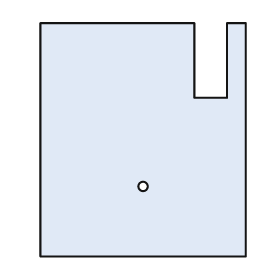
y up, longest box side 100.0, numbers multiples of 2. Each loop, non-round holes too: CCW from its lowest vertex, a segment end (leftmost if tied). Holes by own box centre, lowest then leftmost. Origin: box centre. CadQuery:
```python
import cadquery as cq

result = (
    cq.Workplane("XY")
    .moveTo(-44.0, -50.0)
    .lineTo(44.0, -50.0)
    .lineTo(44.0, 50.0)
    .lineTo(36.0, 50.0)
    .lineTo(36.0, 18.0)
    .lineTo(22.0, 18.0)
    .lineTo(22.0, 50.0)
    .lineTo(-44.0, 50.0)
    .close()
    .moveTo(0.0, -20.0)
    .circle(2.0)
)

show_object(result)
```